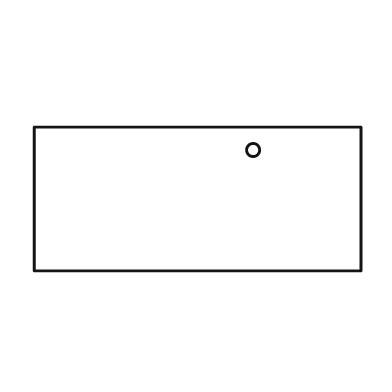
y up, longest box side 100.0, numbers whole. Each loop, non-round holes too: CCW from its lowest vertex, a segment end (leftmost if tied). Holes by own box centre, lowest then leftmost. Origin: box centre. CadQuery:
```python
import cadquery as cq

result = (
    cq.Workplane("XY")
    .moveTo(-50.0, -22.0)
    .lineTo(50.0, -22.0)
    .lineTo(50.0, 22.0)
    .lineTo(-50.0, 22.0)
    .close()
    .moveTo(17.0, 15.0)
    .circle(2.0)
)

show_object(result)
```